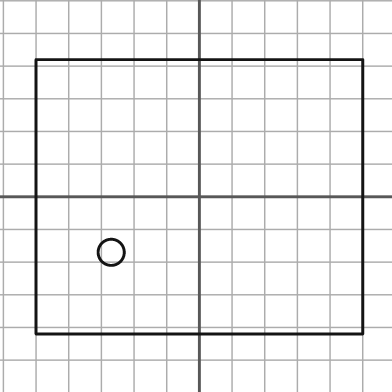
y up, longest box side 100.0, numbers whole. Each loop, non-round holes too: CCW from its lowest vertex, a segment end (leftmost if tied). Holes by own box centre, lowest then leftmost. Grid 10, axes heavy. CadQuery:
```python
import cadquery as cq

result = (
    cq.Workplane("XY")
    .moveTo(-50.0, -42.0)
    .lineTo(50.0, -42.0)
    .lineTo(50.0, 42.0)
    .lineTo(-50.0, 42.0)
    .close()
    .moveTo(-27.0, -17.0)
    .circle(4.0)
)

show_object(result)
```